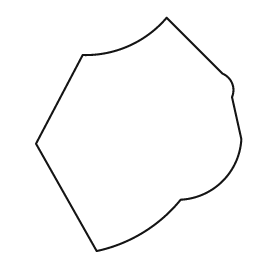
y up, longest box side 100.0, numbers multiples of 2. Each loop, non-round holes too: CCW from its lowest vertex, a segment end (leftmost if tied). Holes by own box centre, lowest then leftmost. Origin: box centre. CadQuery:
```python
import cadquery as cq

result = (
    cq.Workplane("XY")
    .moveTo(-18.0, -50.0)
    .threePointArc((2.0, -42.0), (18.0, -28.0))
    .threePointArc((36.0, -20.0), (44.0, -2.0))
    .lineTo(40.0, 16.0)
    .threePointArc((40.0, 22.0), (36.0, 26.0))
    .lineTo(12.0, 50.0)
    .threePointArc((-4.0, 38.0), (-24.0, 34.0))
    .lineTo(-44.0, -4.0)
    .close()
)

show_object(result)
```